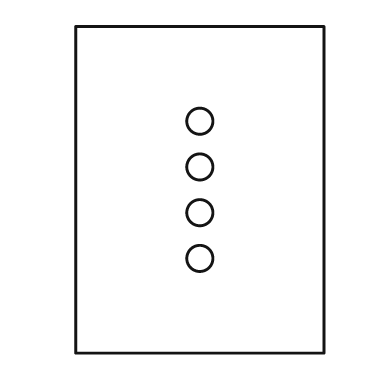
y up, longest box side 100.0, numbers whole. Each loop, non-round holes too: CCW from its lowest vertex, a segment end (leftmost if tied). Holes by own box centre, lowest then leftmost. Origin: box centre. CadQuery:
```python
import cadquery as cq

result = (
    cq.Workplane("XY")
    .moveTo(-38.0, -50.0)
    .lineTo(38.0, -50.0)
    .lineTo(38.0, 50.0)
    .lineTo(-38.0, 50.0)
    .close()
    .moveTo(0.0, -21.0)
    .circle(4.0)
    .moveTo(0.0, -7.0)
    .circle(4.0)
    .moveTo(0.0, 7.0)
    .circle(4.0)
    .moveTo(0.0, 21.0)
    .circle(4.0)
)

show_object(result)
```